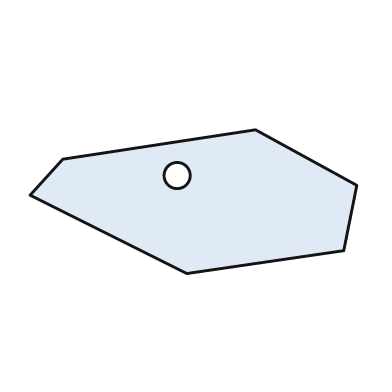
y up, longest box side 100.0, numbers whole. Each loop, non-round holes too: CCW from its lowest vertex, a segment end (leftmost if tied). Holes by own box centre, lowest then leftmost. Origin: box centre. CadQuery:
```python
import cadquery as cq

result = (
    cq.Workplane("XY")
    .moveTo(-2.0, -22.0)
    .lineTo(46.0, -15.0)
    .lineTo(50.0, 5.0)
    .lineTo(19.0, 22.0)
    .lineTo(-40.0, 13.0)
    .lineTo(-50.0, 2.0)
    .close()
    .moveTo(-5.0, 8.0)
    .circle(4.0)
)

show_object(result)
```